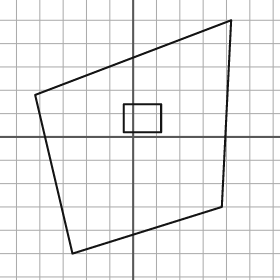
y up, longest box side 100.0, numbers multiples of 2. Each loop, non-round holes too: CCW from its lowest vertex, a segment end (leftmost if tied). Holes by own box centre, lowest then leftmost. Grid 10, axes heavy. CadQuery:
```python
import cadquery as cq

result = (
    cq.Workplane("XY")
    .moveTo(-26.0, -50.0)
    .lineTo(38.0, -30.0)
    .lineTo(42.0, 50.0)
    .lineTo(-42.0, 18.0)
    .close()
    .moveTo(-4.0, 2.0)
    .lineTo(12.0, 2.0)
    .lineTo(12.0, 14.0)
    .lineTo(-4.0, 14.0)
    .close()
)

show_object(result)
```